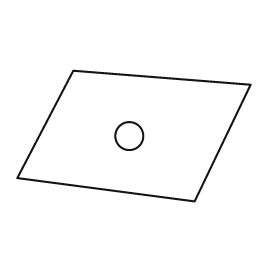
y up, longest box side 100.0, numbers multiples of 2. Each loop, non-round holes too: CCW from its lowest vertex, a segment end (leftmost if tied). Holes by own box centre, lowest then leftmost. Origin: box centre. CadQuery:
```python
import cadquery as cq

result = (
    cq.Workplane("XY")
    .moveTo(26.0, -28.0)
    .lineTo(50.0, 22.0)
    .lineTo(-26.0, 28.0)
    .lineTo(-50.0, -18.0)
    .close()
    .moveTo(-2.0, 0.0)
    .circle(6.0)
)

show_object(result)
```